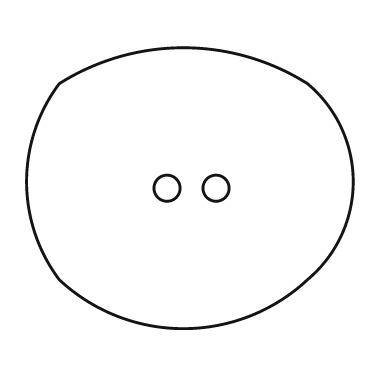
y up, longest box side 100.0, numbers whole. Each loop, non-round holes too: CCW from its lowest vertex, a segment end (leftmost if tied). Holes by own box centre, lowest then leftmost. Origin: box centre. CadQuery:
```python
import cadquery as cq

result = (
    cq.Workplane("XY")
    .moveTo(-40.0, -28.0)
    .threePointArc((-2.0, -43.0), (36.0, -28.0))
    .threePointArc((50.0, 2.0), (36.0, 32.0))
    .threePointArc((-2.0, 43.0), (-40.0, 32.0))
    .threePointArc((-50.0, 2.0), (-40.0, -28.0))
    .close()
    .moveTo(-7.0, 0.0)
    .circle(4.0)
    .moveTo(8.0, 0.0)
    .circle(4.0)
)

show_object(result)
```